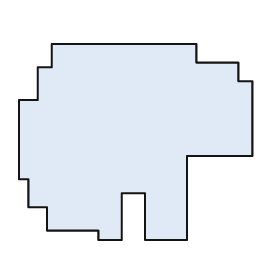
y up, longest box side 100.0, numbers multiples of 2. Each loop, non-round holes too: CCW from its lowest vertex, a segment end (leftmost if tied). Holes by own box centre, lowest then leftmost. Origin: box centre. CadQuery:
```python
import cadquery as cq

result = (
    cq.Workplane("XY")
    .moveTo(-16.0, -42.0)
    .lineTo(-6.0, -42.0)
    .lineTo(-6.0, -22.0)
    .lineTo(4.0, -22.0)
    .lineTo(4.0, -42.0)
    .lineTo(22.0, -42.0)
    .lineTo(22.0, -6.0)
    .lineTo(50.0, -6.0)
    .lineTo(50.0, 26.0)
    .lineTo(44.0, 26.0)
    .lineTo(44.0, 34.0)
    .lineTo(26.0, 34.0)
    .lineTo(26.0, 42.0)
    .lineTo(-36.0, 42.0)
    .lineTo(-36.0, 32.0)
    .lineTo(-42.0, 32.0)
    .lineTo(-42.0, 18.0)
    .lineTo(-50.0, 18.0)
    .lineTo(-50.0, -16.0)
    .lineTo(-46.0, -16.0)
    .lineTo(-46.0, -28.0)
    .lineTo(-38.0, -28.0)
    .lineTo(-38.0, -38.0)
    .lineTo(-16.0, -38.0)
    .close()
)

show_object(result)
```